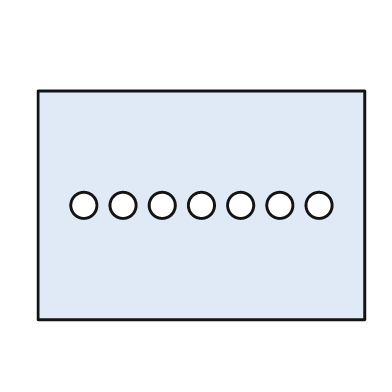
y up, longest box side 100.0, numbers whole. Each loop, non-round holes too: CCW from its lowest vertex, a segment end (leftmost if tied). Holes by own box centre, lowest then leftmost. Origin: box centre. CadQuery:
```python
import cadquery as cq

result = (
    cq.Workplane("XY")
    .moveTo(-50.0, -35.0)
    .lineTo(50.0, -35.0)
    .lineTo(50.0, 35.0)
    .lineTo(-50.0, 35.0)
    .close()
    .moveTo(-36.0, 0.0)
    .circle(4.0)
    .moveTo(-24.0, 0.0)
    .circle(4.0)
    .moveTo(-12.0, 0.0)
    .circle(4.0)
    .moveTo(0.0, 0.0)
    .circle(4.0)
    .moveTo(12.0, 0.0)
    .circle(4.0)
    .moveTo(24.0, 0.0)
    .circle(4.0)
    .moveTo(36.0, 0.0)
    .circle(4.0)
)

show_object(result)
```